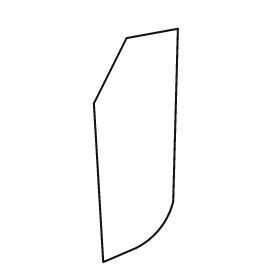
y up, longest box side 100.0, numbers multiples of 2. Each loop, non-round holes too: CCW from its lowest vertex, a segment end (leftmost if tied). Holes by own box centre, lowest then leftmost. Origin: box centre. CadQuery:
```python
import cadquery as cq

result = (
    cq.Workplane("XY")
    .moveTo(-14.0, -50.0)
    .lineTo(0.0, -44.0)
    .threePointArc((10.0, -36.0), (16.0, -24.0))
    .lineTo(18.0, 50.0)
    .lineTo(-4.0, 46.0)
    .lineTo(-18.0, 18.0)
    .close()
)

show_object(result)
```